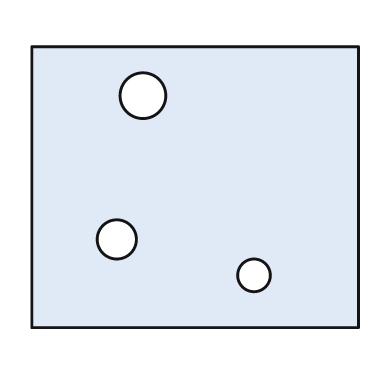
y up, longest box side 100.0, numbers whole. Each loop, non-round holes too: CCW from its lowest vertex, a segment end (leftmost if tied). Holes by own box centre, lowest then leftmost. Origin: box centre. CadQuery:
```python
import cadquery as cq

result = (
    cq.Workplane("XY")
    .moveTo(-50.0, -43.0)
    .lineTo(50.0, -43.0)
    .lineTo(50.0, 43.0)
    .lineTo(-50.0, 43.0)
    .close()
    .moveTo(18.0, -27.0)
    .circle(5.0)
    .moveTo(-24.0, -16.0)
    .circle(6.0)
    .moveTo(-16.0, 28.0)
    .circle(7.0)
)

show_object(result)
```